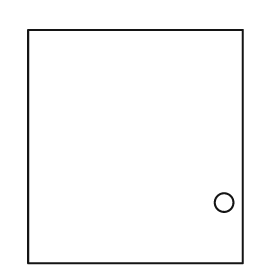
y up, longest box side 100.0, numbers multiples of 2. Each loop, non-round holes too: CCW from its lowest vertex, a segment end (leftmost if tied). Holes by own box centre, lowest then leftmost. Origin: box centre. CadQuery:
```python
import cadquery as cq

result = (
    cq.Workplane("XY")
    .moveTo(-46.0, -50.0)
    .lineTo(46.0, -50.0)
    .lineTo(46.0, 50.0)
    .lineTo(-46.0, 50.0)
    .close()
    .moveTo(38.0, -24.0)
    .circle(4.0)
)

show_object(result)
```